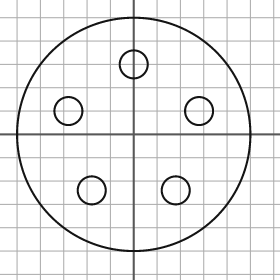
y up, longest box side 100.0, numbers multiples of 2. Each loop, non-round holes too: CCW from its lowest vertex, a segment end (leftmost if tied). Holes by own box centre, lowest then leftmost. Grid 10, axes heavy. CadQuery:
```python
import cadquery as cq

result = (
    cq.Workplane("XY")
    .moveTo(0.0, 0.0)
    .circle(50.0)
    .moveTo(-18.0, -24.0)
    .circle(6.0)
    .moveTo(18.0, -24.0)
    .circle(6.0)
    .moveTo(-28.0, 10.0)
    .circle(6.0)
    .moveTo(28.0, 10.0)
    .circle(6.0)
    .moveTo(0.0, 30.0)
    .circle(6.0)
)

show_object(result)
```